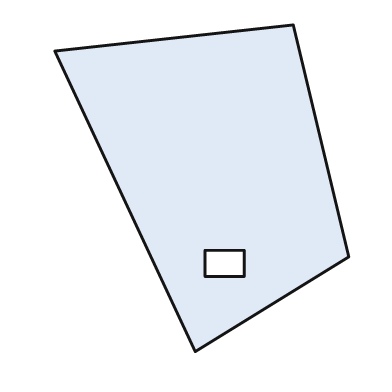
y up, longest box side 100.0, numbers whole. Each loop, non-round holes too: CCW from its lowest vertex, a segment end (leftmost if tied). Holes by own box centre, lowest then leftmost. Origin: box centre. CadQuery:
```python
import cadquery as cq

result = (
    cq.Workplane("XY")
    .moveTo(-2.0, -50.0)
    .lineTo(45.0, -21.0)
    .lineTo(28.0, 50.0)
    .lineTo(-45.0, 42.0)
    .close()
    .moveTo(1.0, -27.0)
    .lineTo(13.0, -27.0)
    .lineTo(13.0, -19.0)
    .lineTo(1.0, -19.0)
    .close()
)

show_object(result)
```